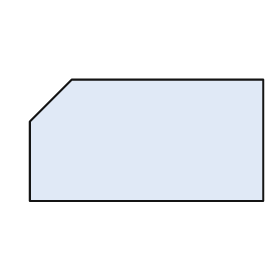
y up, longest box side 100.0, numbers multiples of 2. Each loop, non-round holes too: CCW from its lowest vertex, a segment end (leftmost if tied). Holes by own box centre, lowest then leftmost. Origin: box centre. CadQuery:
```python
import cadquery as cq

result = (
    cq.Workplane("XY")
    .moveTo(-50.0, -26.0)
    .lineTo(50.0, -26.0)
    .lineTo(50.0, 26.0)
    .lineTo(-32.0, 26.0)
    .lineTo(-50.0, 8.0)
    .close()
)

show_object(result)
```